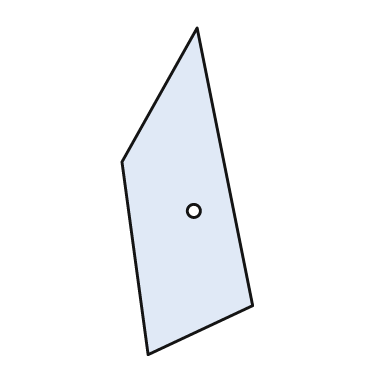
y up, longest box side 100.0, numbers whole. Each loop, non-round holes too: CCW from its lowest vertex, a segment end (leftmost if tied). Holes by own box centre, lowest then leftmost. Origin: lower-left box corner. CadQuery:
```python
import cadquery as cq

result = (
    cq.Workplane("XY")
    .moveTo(8.0, 0.0)
    .lineTo(40.0, 15.0)
    .lineTo(23.0, 100.0)
    .lineTo(0.0, 59.0)
    .close()
    .moveTo(22.0, 44.0)
    .circle(2.0)
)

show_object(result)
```